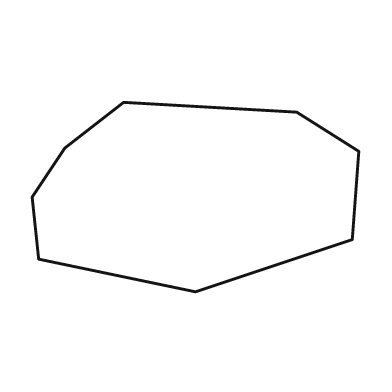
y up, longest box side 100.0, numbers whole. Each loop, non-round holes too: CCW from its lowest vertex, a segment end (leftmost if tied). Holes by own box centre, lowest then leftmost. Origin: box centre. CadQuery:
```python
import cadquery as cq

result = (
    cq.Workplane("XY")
    .moveTo(0.0, -29.0)
    .lineTo(48.0, -13.0)
    .lineTo(50.0, 14.0)
    .lineTo(31.0, 26.0)
    .lineTo(-22.0, 29.0)
    .lineTo(-40.0, 15.0)
    .lineTo(-50.0, 0.0)
    .lineTo(-48.0, -19.0)
    .close()
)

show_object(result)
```